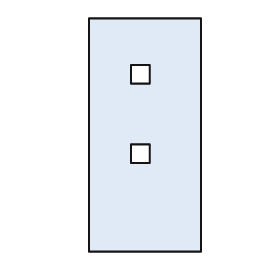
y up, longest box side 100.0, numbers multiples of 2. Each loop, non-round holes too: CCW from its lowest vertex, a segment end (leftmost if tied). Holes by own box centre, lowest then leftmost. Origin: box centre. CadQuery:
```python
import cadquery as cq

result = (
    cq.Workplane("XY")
    .moveTo(-24.0, -50.0)
    .lineTo(24.0, -50.0)
    .lineTo(24.0, 50.0)
    .lineTo(-24.0, 50.0)
    .close()
    .moveTo(-6.0, -12.0)
    .lineTo(2.0, -12.0)
    .lineTo(2.0, -4.0)
    .lineTo(-6.0, -4.0)
    .close()
    .moveTo(-6.0, 22.0)
    .lineTo(2.0, 22.0)
    .lineTo(2.0, 30.0)
    .lineTo(-6.0, 30.0)
    .close()
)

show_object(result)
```